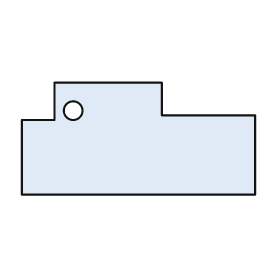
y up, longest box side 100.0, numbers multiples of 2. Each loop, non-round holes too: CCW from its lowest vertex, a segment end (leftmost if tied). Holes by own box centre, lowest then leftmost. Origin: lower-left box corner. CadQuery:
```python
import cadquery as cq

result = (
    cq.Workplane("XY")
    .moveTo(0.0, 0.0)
    .lineTo(100.0, 0.0)
    .lineTo(100.0, 34.0)
    .lineTo(60.0, 34.0)
    .lineTo(60.0, 48.0)
    .lineTo(14.0, 48.0)
    .lineTo(14.0, 32.0)
    .lineTo(0.0, 32.0)
    .close()
    .moveTo(22.0, 36.0)
    .circle(4.0)
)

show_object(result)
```